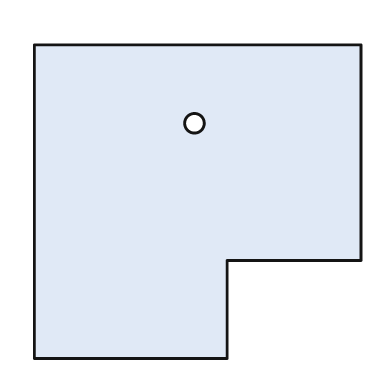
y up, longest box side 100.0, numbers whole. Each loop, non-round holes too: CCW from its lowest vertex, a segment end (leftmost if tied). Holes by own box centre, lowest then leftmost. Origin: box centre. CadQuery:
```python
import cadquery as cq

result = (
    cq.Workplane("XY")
    .moveTo(-50.0, -48.0)
    .lineTo(9.0, -48.0)
    .lineTo(9.0, -18.0)
    .lineTo(50.0, -18.0)
    .lineTo(50.0, 48.0)
    .lineTo(-50.0, 48.0)
    .close()
    .moveTo(-1.0, 24.0)
    .circle(3.0)
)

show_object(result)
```